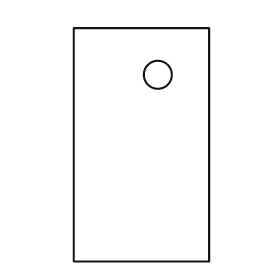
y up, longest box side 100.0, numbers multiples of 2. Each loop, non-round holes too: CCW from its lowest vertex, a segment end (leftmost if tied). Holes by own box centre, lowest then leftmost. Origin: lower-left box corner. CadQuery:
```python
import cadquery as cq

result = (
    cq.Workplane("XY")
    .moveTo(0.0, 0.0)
    .lineTo(58.0, 0.0)
    .lineTo(58.0, 100.0)
    .lineTo(0.0, 100.0)
    .close()
    .moveTo(36.0, 80.0)
    .circle(6.0)
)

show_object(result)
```